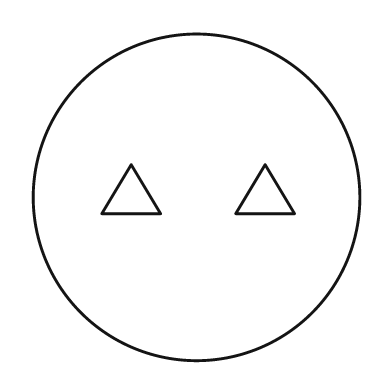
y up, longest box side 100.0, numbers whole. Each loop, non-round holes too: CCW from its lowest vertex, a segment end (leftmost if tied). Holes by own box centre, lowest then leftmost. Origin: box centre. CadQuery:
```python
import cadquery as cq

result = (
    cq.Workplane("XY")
    .moveTo(0.0, 0.0)
    .circle(50.0)
    .moveTo(-29.0, -5.0)
    .lineTo(-11.0, -5.0)
    .lineTo(-20.0, 10.0)
    .close()
    .moveTo(12.0, -5.0)
    .lineTo(30.0, -5.0)
    .lineTo(21.0, 10.0)
    .close()
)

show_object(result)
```